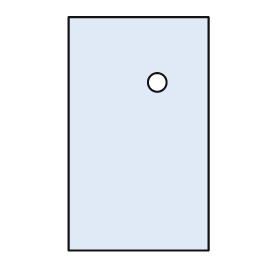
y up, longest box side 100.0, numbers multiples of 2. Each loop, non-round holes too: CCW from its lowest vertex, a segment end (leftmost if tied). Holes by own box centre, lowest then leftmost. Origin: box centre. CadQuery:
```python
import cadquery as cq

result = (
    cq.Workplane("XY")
    .moveTo(-30.0, -50.0)
    .lineTo(30.0, -50.0)
    .lineTo(30.0, 50.0)
    .lineTo(-30.0, 50.0)
    .close()
    .moveTo(8.0, 22.0)
    .circle(4.0)
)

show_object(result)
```